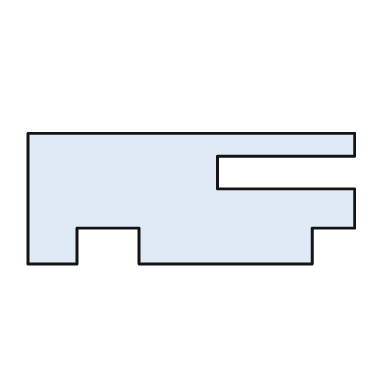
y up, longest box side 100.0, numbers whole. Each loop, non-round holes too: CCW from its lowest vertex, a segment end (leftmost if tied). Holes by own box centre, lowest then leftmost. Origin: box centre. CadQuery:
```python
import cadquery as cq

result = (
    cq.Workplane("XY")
    .moveTo(-50.0, -20.0)
    .lineTo(-35.0, -20.0)
    .lineTo(-35.0, -9.0)
    .lineTo(-16.0, -9.0)
    .lineTo(-16.0, -20.0)
    .lineTo(37.0, -20.0)
    .lineTo(37.0, -9.0)
    .lineTo(50.0, -9.0)
    .lineTo(50.0, 3.0)
    .lineTo(8.0, 3.0)
    .lineTo(8.0, 13.0)
    .lineTo(50.0, 13.0)
    .lineTo(50.0, 20.0)
    .lineTo(-50.0, 20.0)
    .close()
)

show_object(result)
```